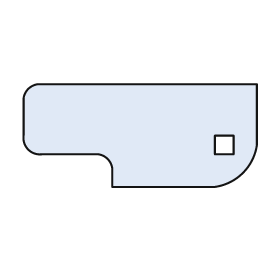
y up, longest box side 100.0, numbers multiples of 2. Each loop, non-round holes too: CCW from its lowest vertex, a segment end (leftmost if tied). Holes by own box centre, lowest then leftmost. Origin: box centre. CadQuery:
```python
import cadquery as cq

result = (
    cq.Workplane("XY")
    .moveTo(-12.0, -22.0)
    .lineTo(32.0, -22.0)
    .threePointArc((44.0, -16.0), (50.0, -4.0))
    .lineTo(50.0, 22.0)
    .lineTo(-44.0, 22.0)
    .threePointArc((-48.0, 20.0), (-50.0, 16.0))
    .lineTo(-50.0, 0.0)
    .threePointArc((-48.0, -6.0), (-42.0, -8.0))
    .lineTo(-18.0, -8.0)
    .threePointArc((-14.0, -10.0), (-12.0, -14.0))
    .close()
    .moveTo(32.0, -8.0)
    .lineTo(40.0, -8.0)
    .lineTo(40.0, 0.0)
    .lineTo(32.0, 0.0)
    .close()
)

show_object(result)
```